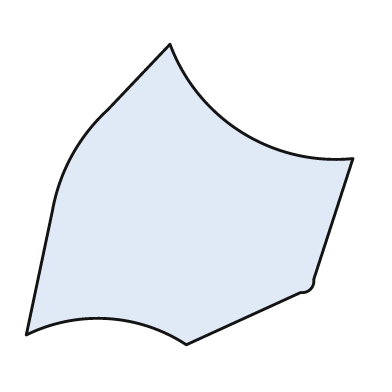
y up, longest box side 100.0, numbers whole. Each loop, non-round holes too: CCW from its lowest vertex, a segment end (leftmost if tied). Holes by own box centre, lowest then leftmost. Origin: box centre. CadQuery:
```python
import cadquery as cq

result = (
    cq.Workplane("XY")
    .moveTo(-1.0, -46.0)
    .lineTo(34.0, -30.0)
    .threePointArc((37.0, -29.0), (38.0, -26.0))
    .lineTo(50.0, 11.0)
    .threePointArc((16.0, 19.0), (-6.0, 46.0))
    .lineTo(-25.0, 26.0)
    .threePointArc((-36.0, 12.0), (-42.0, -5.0))
    .lineTo(-50.0, -43.0)
    .threePointArc((-25.0, -38.0), (-1.0, -46.0))
    .close()
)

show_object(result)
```